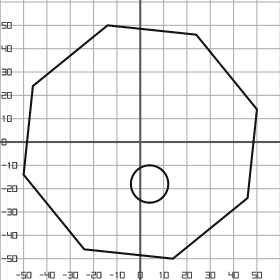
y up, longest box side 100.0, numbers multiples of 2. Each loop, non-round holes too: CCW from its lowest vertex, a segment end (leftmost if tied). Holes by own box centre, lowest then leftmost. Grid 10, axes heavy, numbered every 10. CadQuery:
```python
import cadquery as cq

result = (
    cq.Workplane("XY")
    .moveTo(14.0, -50.0)
    .lineTo(46.0, -24.0)
    .lineTo(50.0, 14.0)
    .lineTo(24.0, 46.0)
    .lineTo(-14.0, 50.0)
    .lineTo(-46.0, 24.0)
    .lineTo(-50.0, -14.0)
    .lineTo(-24.0, -46.0)
    .close()
    .moveTo(4.0, -18.0)
    .circle(8.0)
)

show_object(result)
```